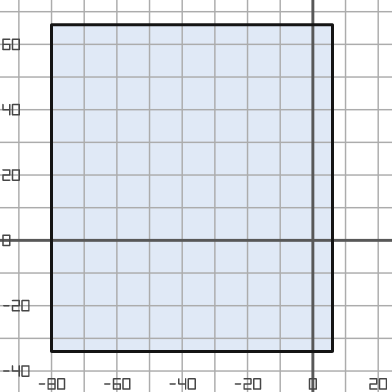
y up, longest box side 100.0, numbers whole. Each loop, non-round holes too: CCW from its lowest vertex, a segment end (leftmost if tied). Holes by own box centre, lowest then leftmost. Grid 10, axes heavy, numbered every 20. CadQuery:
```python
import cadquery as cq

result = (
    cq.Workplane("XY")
    .moveTo(-80.0, -34.0)
    .lineTo(6.0, -34.0)
    .lineTo(6.0, 66.0)
    .lineTo(-80.0, 66.0)
    .close()
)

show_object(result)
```